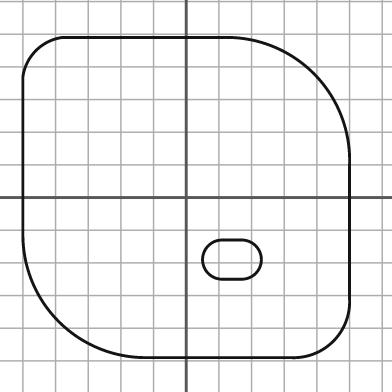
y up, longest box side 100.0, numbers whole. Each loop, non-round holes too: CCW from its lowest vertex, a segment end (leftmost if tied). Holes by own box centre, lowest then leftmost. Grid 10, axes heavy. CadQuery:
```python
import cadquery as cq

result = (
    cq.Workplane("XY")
    .moveTo(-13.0, -49.0)
    .lineTo(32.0, -49.0)
    .threePointArc((45.0, -44.0), (50.0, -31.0))
    .lineTo(50.0, 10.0)
    .threePointArc((39.0, 38.0), (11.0, 49.0))
    .lineTo(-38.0, 49.0)
    .threePointArc((-46.0, 45.0), (-50.0, 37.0))
    .lineTo(-50.0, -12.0)
    .threePointArc((-39.0, -38.0), (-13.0, -49.0))
    .close()
    .moveTo(11.0, -25.0)
    .lineTo(17.0, -25.0)
    .threePointArc((23.0, -19.0), (17.0, -13.0))
    .lineTo(11.0, -13.0)
    .threePointArc((5.0, -19.0), (11.0, -25.0))
    .close()
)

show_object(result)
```